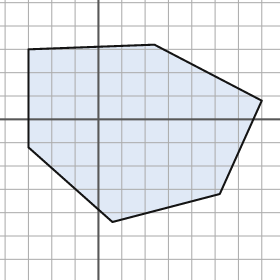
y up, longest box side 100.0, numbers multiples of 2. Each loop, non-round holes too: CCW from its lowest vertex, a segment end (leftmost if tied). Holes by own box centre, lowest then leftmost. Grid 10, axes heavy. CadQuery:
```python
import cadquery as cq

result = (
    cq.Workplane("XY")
    .moveTo(6.0, -44.0)
    .lineTo(52.0, -32.0)
    .lineTo(70.0, 8.0)
    .lineTo(24.0, 32.0)
    .lineTo(-30.0, 30.0)
    .lineTo(-30.0, -12.0)
    .close()
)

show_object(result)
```